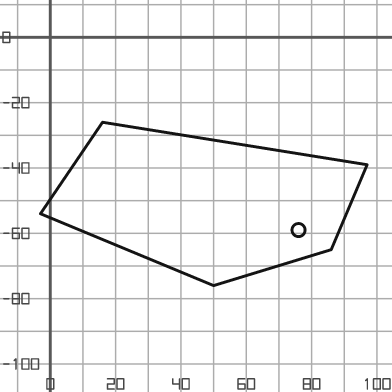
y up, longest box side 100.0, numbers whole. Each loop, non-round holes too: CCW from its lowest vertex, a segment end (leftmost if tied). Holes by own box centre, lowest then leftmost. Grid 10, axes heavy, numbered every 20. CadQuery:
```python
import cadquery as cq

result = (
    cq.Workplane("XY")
    .moveTo(50.0, -76.0)
    .lineTo(86.0, -65.0)
    .lineTo(97.0, -39.0)
    .lineTo(16.0, -26.0)
    .lineTo(-3.0, -54.0)
    .close()
    .moveTo(76.0, -59.0)
    .circle(2.0)
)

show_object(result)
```